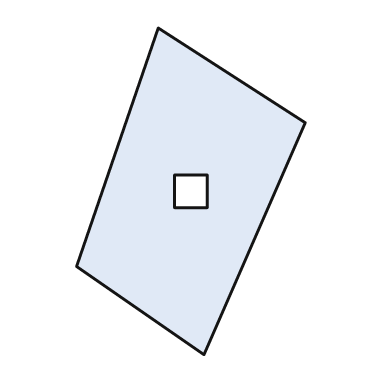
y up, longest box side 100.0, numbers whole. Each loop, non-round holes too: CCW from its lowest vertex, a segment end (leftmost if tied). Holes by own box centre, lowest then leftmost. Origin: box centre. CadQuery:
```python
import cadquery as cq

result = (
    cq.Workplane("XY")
    .moveTo(4.0, -50.0)
    .lineTo(35.0, 21.0)
    .lineTo(-10.0, 50.0)
    .lineTo(-35.0, -23.0)
    .close()
    .moveTo(-5.0, -5.0)
    .lineTo(5.0, -5.0)
    .lineTo(5.0, 5.0)
    .lineTo(-5.0, 5.0)
    .close()
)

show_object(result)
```